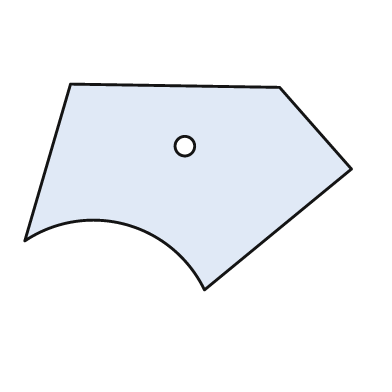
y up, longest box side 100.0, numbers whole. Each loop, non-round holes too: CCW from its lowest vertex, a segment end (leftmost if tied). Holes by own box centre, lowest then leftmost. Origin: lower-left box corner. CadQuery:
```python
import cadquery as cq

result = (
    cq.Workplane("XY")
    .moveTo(55.0, 0.0)
    .lineTo(100.0, 37.0)
    .lineTo(78.0, 62.0)
    .lineTo(14.0, 63.0)
    .lineTo(0.0, 15.0)
    .threePointArc((31.0, 20.0), (55.0, 0.0))
    .close()
    .moveTo(49.0, 44.0)
    .circle(3.0)
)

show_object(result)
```